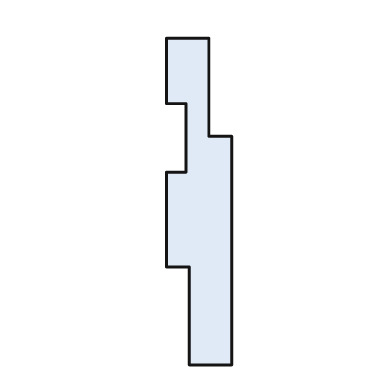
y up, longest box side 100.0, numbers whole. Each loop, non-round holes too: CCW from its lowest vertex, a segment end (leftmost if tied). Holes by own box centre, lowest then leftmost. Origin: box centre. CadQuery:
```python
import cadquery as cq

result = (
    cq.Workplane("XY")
    .moveTo(-3.0, -50.0)
    .lineTo(10.0, -50.0)
    .lineTo(10.0, 20.0)
    .lineTo(3.0, 20.0)
    .lineTo(3.0, 50.0)
    .lineTo(-10.0, 50.0)
    .lineTo(-10.0, 30.0)
    .lineTo(-4.0, 30.0)
    .lineTo(-4.0, 9.0)
    .lineTo(-10.0, 9.0)
    .lineTo(-10.0, -20.0)
    .lineTo(-3.0, -20.0)
    .close()
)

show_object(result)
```